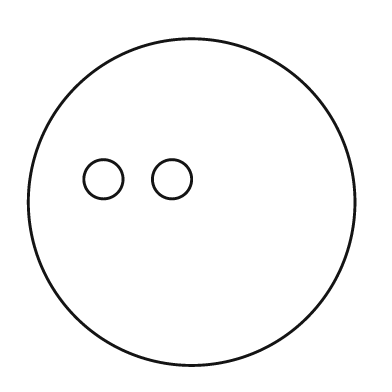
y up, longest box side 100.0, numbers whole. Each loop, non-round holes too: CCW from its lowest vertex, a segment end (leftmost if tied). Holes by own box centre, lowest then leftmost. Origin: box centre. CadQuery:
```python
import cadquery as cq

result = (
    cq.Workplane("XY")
    .moveTo(0.0, 0.0)
    .circle(50.0)
    .moveTo(-27.0, 7.0)
    .circle(6.0)
    .moveTo(-6.0, 7.0)
    .circle(6.0)
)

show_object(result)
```